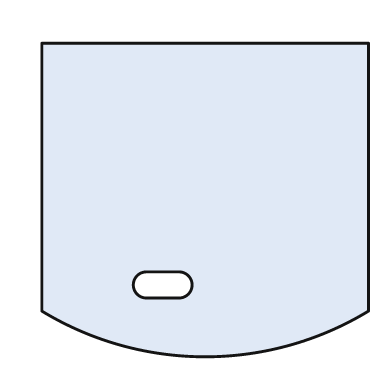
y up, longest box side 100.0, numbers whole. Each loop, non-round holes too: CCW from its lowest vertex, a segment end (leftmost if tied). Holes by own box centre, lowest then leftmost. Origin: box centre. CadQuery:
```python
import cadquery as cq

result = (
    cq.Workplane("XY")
    .moveTo(-50.0, -34.0)
    .threePointArc((0.0, -48.0), (50.0, -34.0))
    .lineTo(50.0, 48.0)
    .lineTo(-50.0, 48.0)
    .close()
    .moveTo(-18.0, -30.0)
    .lineTo(-8.0, -30.0)
    .threePointArc((-4.0, -26.0), (-8.0, -22.0))
    .lineTo(-18.0, -22.0)
    .threePointArc((-22.0, -26.0), (-18.0, -30.0))
    .close()
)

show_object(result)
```